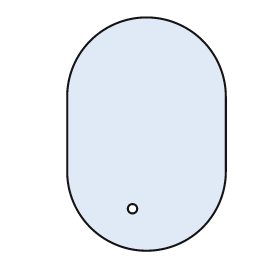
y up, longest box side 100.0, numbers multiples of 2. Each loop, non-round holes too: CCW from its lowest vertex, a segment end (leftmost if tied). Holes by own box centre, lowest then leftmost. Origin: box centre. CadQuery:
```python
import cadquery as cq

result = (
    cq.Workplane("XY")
    .moveTo(-34.0, -16.0)
    .threePointArc((0.0, -50.0), (34.0, -16.0))
    .lineTo(34.0, 16.0)
    .threePointArc((0.0, 50.0), (-34.0, 16.0))
    .close()
    .moveTo(-6.0, -32.0)
    .circle(2.0)
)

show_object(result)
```